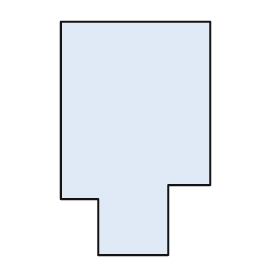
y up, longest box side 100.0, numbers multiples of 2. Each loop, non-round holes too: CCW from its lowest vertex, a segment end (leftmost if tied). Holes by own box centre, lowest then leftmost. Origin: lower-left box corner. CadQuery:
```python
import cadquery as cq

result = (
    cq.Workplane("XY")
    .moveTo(16.0, 0.0)
    .lineTo(46.0, 0.0)
    .lineTo(46.0, 30.0)
    .lineTo(64.0, 30.0)
    .lineTo(64.0, 100.0)
    .lineTo(0.0, 100.0)
    .lineTo(0.0, 24.0)
    .lineTo(16.0, 24.0)
    .close()
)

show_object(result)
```